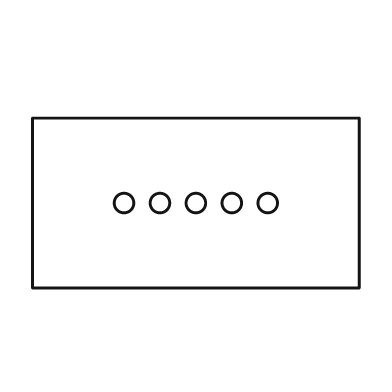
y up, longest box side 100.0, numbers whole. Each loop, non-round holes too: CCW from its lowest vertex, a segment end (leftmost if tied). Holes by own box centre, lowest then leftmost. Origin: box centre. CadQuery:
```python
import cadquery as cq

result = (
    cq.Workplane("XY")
    .moveTo(-50.0, -26.0)
    .lineTo(50.0, -26.0)
    .lineTo(50.0, 26.0)
    .lineTo(-50.0, 26.0)
    .close()
    .moveTo(-22.0, 0.0)
    .circle(3.0)
    .moveTo(-11.0, 0.0)
    .circle(3.0)
    .moveTo(0.0, 0.0)
    .circle(3.0)
    .moveTo(11.0, 0.0)
    .circle(3.0)
    .moveTo(22.0, 0.0)
    .circle(3.0)
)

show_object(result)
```